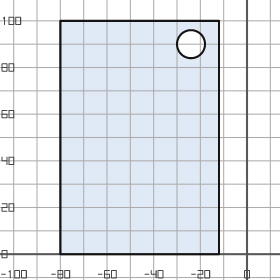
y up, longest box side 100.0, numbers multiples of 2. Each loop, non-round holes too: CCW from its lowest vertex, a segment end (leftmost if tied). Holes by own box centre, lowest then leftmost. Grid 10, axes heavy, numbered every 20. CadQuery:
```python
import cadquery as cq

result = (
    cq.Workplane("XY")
    .moveTo(-80.0, 0.0)
    .lineTo(-12.0, 0.0)
    .lineTo(-12.0, 100.0)
    .lineTo(-80.0, 100.0)
    .close()
    .moveTo(-24.0, 90.0)
    .circle(6.0)
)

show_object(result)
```